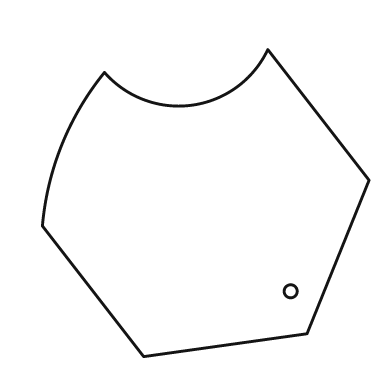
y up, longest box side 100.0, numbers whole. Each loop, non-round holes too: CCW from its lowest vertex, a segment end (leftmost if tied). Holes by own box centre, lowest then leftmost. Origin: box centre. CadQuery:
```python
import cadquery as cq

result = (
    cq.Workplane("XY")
    .moveTo(-19.0, -47.0)
    .lineTo(31.0, -40.0)
    .lineTo(50.0, 7.0)
    .lineTo(19.0, 47.0)
    .threePointArc((-4.0, 30.0), (-31.0, 40.0))
    .threePointArc((-44.0, 18.0), (-50.0, -7.0))
    .close()
    .moveTo(26.0, -27.0)
    .circle(2.0)
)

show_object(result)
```